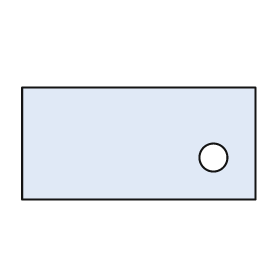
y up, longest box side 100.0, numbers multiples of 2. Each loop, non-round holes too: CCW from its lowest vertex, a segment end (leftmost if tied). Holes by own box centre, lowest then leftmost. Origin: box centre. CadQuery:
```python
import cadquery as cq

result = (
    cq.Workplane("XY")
    .moveTo(-50.0, -24.0)
    .lineTo(50.0, -24.0)
    .lineTo(50.0, 24.0)
    .lineTo(-50.0, 24.0)
    .close()
    .moveTo(32.0, -6.0)
    .circle(6.0)
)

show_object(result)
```